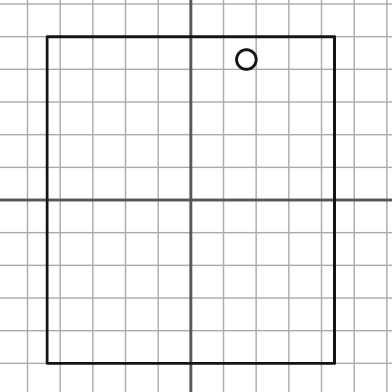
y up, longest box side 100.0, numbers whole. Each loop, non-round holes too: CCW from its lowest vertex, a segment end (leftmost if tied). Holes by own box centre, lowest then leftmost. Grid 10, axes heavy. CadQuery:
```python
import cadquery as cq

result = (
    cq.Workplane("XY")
    .moveTo(-44.0, -50.0)
    .lineTo(44.0, -50.0)
    .lineTo(44.0, 50.0)
    .lineTo(-44.0, 50.0)
    .close()
    .moveTo(17.0, 43.0)
    .circle(3.0)
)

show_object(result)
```